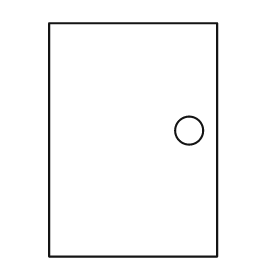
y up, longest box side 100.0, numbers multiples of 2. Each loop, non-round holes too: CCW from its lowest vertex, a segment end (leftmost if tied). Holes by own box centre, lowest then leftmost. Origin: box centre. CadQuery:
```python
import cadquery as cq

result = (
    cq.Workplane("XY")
    .moveTo(-36.0, -50.0)
    .lineTo(36.0, -50.0)
    .lineTo(36.0, 50.0)
    .lineTo(-36.0, 50.0)
    .close()
    .moveTo(24.0, 4.0)
    .circle(6.0)
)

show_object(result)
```